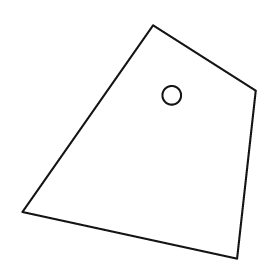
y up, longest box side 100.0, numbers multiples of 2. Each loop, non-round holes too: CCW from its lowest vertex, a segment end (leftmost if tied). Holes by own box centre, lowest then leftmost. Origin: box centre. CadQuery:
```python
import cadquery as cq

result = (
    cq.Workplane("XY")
    .moveTo(42.0, -50.0)
    .lineTo(50.0, 22.0)
    .lineTo(6.0, 50.0)
    .lineTo(-50.0, -30.0)
    .close()
    .moveTo(14.0, 20.0)
    .circle(4.0)
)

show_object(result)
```